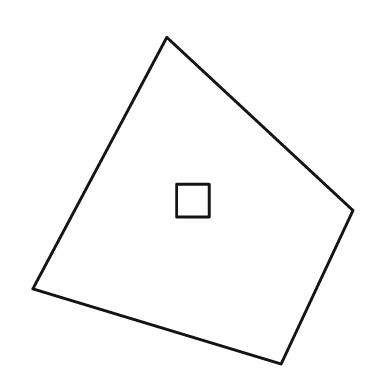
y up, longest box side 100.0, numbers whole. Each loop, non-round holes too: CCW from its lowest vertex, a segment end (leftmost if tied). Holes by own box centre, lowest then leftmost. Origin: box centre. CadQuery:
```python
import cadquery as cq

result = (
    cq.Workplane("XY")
    .moveTo(27.0, -50.0)
    .lineTo(49.0, -3.0)
    .lineTo(-8.0, 50.0)
    .lineTo(-49.0, -27.0)
    .close()
    .moveTo(-5.0, -5.0)
    .lineTo(5.0, -5.0)
    .lineTo(5.0, 5.0)
    .lineTo(-5.0, 5.0)
    .close()
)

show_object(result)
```